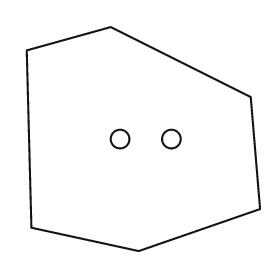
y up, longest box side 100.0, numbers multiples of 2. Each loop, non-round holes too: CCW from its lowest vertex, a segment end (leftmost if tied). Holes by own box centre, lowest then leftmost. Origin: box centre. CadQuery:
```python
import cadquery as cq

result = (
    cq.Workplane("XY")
    .moveTo(-2.0, -48.0)
    .lineTo(50.0, -30.0)
    .lineTo(46.0, 18.0)
    .lineTo(-14.0, 48.0)
    .lineTo(-50.0, 38.0)
    .lineTo(-48.0, -38.0)
    .close()
    .moveTo(-10.0, 0.0)
    .circle(4.0)
    .moveTo(12.0, 0.0)
    .circle(4.0)
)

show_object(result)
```